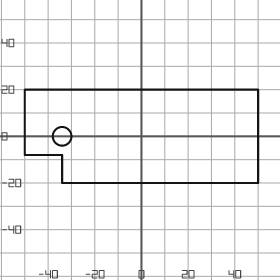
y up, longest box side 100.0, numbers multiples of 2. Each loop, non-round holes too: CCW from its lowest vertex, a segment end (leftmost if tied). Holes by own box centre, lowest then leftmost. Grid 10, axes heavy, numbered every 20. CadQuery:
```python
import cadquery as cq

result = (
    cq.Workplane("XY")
    .moveTo(-34.0, -20.0)
    .lineTo(50.0, -20.0)
    .lineTo(50.0, 20.0)
    .lineTo(-50.0, 20.0)
    .lineTo(-50.0, -8.0)
    .lineTo(-34.0, -8.0)
    .close()
    .moveTo(-34.0, 0.0)
    .circle(4.0)
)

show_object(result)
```